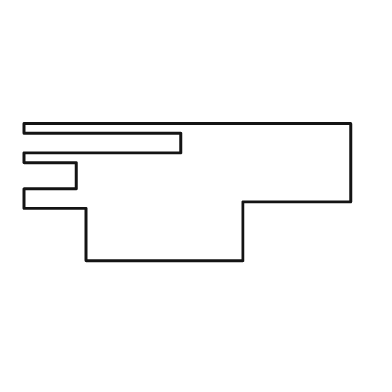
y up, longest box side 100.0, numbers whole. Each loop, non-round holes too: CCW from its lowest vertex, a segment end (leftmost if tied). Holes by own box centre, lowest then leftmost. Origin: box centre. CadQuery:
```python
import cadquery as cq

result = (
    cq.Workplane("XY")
    .moveTo(-31.0, -21.0)
    .lineTo(17.0, -21.0)
    .lineTo(17.0, -3.0)
    .lineTo(50.0, -3.0)
    .lineTo(50.0, 21.0)
    .lineTo(-50.0, 21.0)
    .lineTo(-50.0, 18.0)
    .lineTo(-2.0, 18.0)
    .lineTo(-2.0, 12.0)
    .lineTo(-50.0, 12.0)
    .lineTo(-50.0, 9.0)
    .lineTo(-34.0, 9.0)
    .lineTo(-34.0, 1.0)
    .lineTo(-50.0, 1.0)
    .lineTo(-50.0, -5.0)
    .lineTo(-31.0, -5.0)
    .close()
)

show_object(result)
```